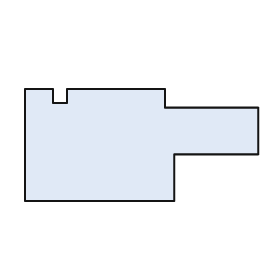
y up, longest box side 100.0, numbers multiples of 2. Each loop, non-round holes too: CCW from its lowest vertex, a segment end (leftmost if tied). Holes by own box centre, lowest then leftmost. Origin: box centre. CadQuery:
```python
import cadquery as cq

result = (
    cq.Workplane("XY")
    .moveTo(-50.0, -24.0)
    .lineTo(14.0, -24.0)
    .lineTo(14.0, -4.0)
    .lineTo(50.0, -4.0)
    .lineTo(50.0, 16.0)
    .lineTo(10.0, 16.0)
    .lineTo(10.0, 24.0)
    .lineTo(-32.0, 24.0)
    .lineTo(-32.0, 18.0)
    .lineTo(-38.0, 18.0)
    .lineTo(-38.0, 24.0)
    .lineTo(-50.0, 24.0)
    .close()
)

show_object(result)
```